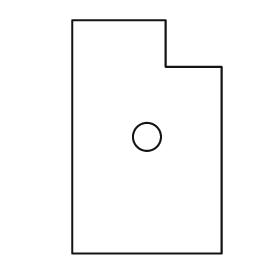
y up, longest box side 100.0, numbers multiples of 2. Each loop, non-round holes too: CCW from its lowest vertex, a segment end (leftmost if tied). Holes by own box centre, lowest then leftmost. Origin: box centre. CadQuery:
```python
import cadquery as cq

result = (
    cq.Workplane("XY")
    .moveTo(-32.0, -50.0)
    .lineTo(32.0, -50.0)
    .lineTo(32.0, 30.0)
    .lineTo(8.0, 30.0)
    .lineTo(8.0, 50.0)
    .lineTo(-32.0, 50.0)
    .close()
    .moveTo(0.0, 0.0)
    .circle(6.0)
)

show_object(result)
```